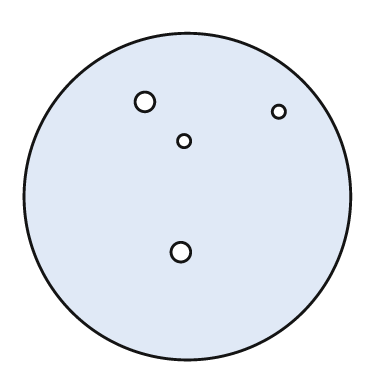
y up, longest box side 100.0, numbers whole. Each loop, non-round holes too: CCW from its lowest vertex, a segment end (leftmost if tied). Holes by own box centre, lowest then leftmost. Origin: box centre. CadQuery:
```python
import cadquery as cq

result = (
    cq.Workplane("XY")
    .moveTo(0.0, 0.0)
    .circle(50.0)
    .moveTo(-2.0, -17.0)
    .circle(3.0)
    .moveTo(-1.0, 17.0)
    .circle(2.0)
    .moveTo(28.0, 26.0)
    .circle(2.0)
    .moveTo(-13.0, 29.0)
    .circle(3.0)
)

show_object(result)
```